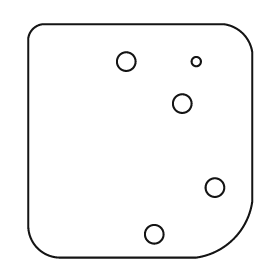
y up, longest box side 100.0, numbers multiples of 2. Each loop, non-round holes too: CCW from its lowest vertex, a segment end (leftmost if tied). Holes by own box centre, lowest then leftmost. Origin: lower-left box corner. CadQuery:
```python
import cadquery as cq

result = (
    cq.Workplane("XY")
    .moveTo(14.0, 0.0)
    .lineTo(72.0, 0.0)
    .threePointArc((88.0, 8.0), (96.0, 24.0))
    .lineTo(96.0, 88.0)
    .threePointArc((92.0, 96.0), (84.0, 100.0))
    .lineTo(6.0, 100.0)
    .threePointArc((2.0, 98.0), (0.0, 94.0))
    .lineTo(0.0, 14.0)
    .threePointArc((4.0, 4.0), (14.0, 0.0))
    .close()
    .moveTo(54.0, 10.0)
    .circle(4.0)
    .moveTo(80.0, 30.0)
    .circle(4.0)
    .moveTo(66.0, 66.0)
    .circle(4.0)
    .moveTo(42.0, 84.0)
    .circle(4.0)
    .moveTo(72.0, 84.0)
    .circle(2.0)
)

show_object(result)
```